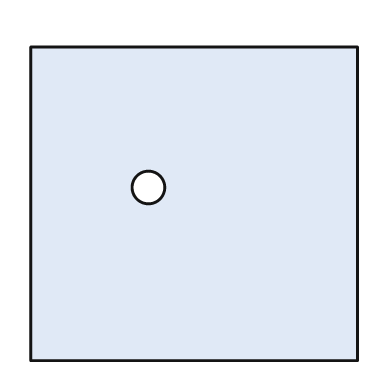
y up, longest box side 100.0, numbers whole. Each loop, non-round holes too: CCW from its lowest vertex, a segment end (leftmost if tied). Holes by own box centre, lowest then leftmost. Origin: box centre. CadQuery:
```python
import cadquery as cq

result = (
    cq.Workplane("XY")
    .moveTo(-50.0, -48.0)
    .lineTo(50.0, -48.0)
    .lineTo(50.0, 48.0)
    .lineTo(-50.0, 48.0)
    .close()
    .moveTo(-14.0, 5.0)
    .circle(5.0)
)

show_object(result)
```